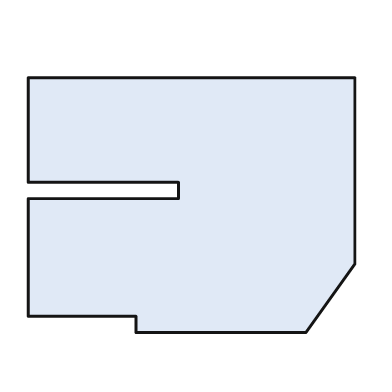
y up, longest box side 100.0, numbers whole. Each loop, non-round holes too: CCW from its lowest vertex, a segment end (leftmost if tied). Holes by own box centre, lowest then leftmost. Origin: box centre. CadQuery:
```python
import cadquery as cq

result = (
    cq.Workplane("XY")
    .moveTo(-17.0, -39.0)
    .lineTo(35.0, -39.0)
    .lineTo(50.0, -18.0)
    .lineTo(50.0, 39.0)
    .lineTo(-50.0, 39.0)
    .lineTo(-50.0, 7.0)
    .lineTo(-4.0, 7.0)
    .lineTo(-4.0, 2.0)
    .lineTo(-50.0, 2.0)
    .lineTo(-50.0, -34.0)
    .lineTo(-17.0, -34.0)
    .close()
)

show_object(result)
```